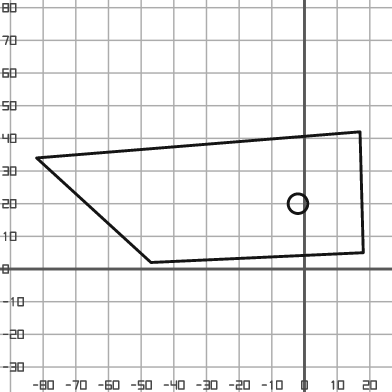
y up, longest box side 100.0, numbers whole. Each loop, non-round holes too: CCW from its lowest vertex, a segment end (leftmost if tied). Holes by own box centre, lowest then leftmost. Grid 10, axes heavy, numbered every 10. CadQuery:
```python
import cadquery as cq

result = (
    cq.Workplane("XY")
    .moveTo(-47.0, 2.0)
    .lineTo(18.0, 5.0)
    .lineTo(17.0, 42.0)
    .lineTo(-82.0, 34.0)
    .close()
    .moveTo(-2.0, 20.0)
    .circle(3.0)
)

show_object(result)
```